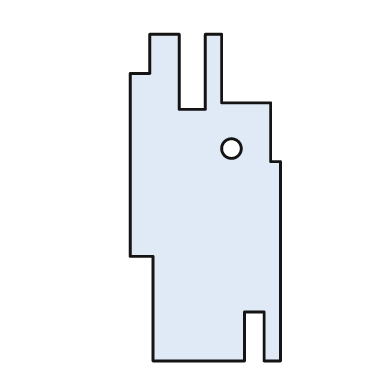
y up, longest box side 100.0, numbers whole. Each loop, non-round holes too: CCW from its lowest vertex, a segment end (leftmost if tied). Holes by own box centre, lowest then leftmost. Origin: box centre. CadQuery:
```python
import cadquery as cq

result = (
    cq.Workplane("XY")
    .moveTo(-16.0, -50.0)
    .lineTo(12.0, -50.0)
    .lineTo(12.0, -35.0)
    .lineTo(18.0, -35.0)
    .lineTo(18.0, -50.0)
    .lineTo(23.0, -50.0)
    .lineTo(23.0, 11.0)
    .lineTo(20.0, 11.0)
    .lineTo(20.0, 29.0)
    .lineTo(5.0, 29.0)
    .lineTo(5.0, 50.0)
    .lineTo(0.0, 50.0)
    .lineTo(0.0, 27.0)
    .lineTo(-8.0, 27.0)
    .lineTo(-8.0, 50.0)
    .lineTo(-17.0, 50.0)
    .lineTo(-17.0, 38.0)
    .lineTo(-23.0, 38.0)
    .lineTo(-23.0, -18.0)
    .lineTo(-16.0, -18.0)
    .close()
    .moveTo(8.0, 15.0)
    .circle(3.0)
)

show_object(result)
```